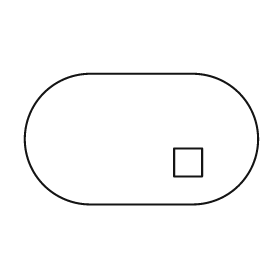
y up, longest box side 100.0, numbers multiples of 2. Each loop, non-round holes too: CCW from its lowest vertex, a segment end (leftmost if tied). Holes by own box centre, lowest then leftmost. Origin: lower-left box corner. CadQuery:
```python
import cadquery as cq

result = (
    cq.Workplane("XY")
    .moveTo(28.0, 0.0)
    .lineTo(72.0, 0.0)
    .threePointArc((100.0, 28.0), (72.0, 56.0))
    .lineTo(28.0, 56.0)
    .threePointArc((0.0, 28.0), (28.0, 0.0))
    .close()
    .moveTo(64.0, 12.0)
    .lineTo(76.0, 12.0)
    .lineTo(76.0, 24.0)
    .lineTo(64.0, 24.0)
    .close()
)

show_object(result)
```